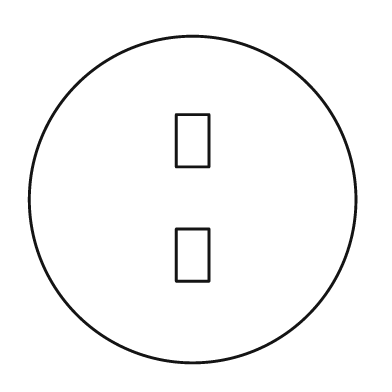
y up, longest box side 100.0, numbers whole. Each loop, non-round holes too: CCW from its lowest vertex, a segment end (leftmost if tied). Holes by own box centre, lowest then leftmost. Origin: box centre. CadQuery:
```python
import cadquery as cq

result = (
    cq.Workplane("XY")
    .moveTo(0.0, 0.0)
    .circle(50.0)
    .moveTo(-5.0, -25.0)
    .lineTo(5.0, -25.0)
    .lineTo(5.0, -9.0)
    .lineTo(-5.0, -9.0)
    .close()
    .moveTo(-5.0, 10.0)
    .lineTo(5.0, 10.0)
    .lineTo(5.0, 26.0)
    .lineTo(-5.0, 26.0)
    .close()
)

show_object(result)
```